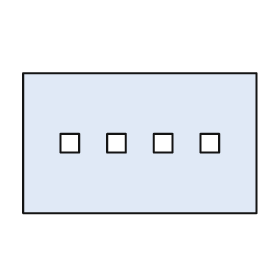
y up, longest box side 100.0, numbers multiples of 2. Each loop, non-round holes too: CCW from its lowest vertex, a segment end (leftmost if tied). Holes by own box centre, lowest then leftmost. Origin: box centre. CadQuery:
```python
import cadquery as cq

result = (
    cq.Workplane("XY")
    .moveTo(-50.0, -30.0)
    .lineTo(50.0, -30.0)
    .lineTo(50.0, 30.0)
    .lineTo(-50.0, 30.0)
    .close()
    .moveTo(-34.0, -4.0)
    .lineTo(-26.0, -4.0)
    .lineTo(-26.0, 4.0)
    .lineTo(-34.0, 4.0)
    .close()
    .moveTo(-14.0, -4.0)
    .lineTo(-6.0, -4.0)
    .lineTo(-6.0, 4.0)
    .lineTo(-14.0, 4.0)
    .close()
    .moveTo(6.0, -4.0)
    .lineTo(14.0, -4.0)
    .lineTo(14.0, 4.0)
    .lineTo(6.0, 4.0)
    .close()
    .moveTo(26.0, -4.0)
    .lineTo(34.0, -4.0)
    .lineTo(34.0, 4.0)
    .lineTo(26.0, 4.0)
    .close()
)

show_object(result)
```